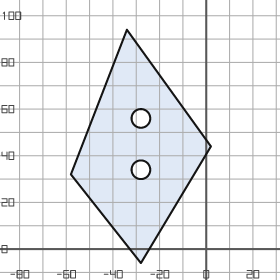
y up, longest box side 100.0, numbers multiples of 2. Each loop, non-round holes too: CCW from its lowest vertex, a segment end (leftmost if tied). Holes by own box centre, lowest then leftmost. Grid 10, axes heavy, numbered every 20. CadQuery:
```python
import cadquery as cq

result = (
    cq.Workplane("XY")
    .moveTo(-28.0, -6.0)
    .lineTo(2.0, 44.0)
    .lineTo(-34.0, 94.0)
    .lineTo(-58.0, 32.0)
    .close()
    .moveTo(-28.0, 34.0)
    .circle(4.0)
    .moveTo(-28.0, 56.0)
    .circle(4.0)
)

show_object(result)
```